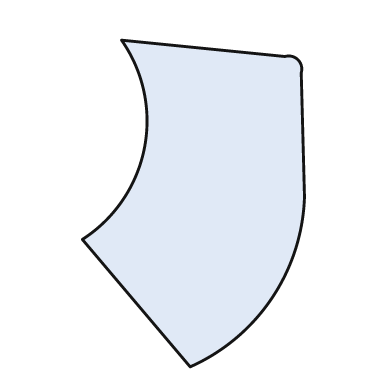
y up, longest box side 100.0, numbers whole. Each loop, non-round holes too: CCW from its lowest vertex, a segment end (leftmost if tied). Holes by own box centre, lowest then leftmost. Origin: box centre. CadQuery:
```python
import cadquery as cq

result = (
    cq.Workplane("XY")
    .moveTo(-1.0, -50.0)
    .threePointArc((24.0, -29.0), (34.0, 2.0))
    .lineTo(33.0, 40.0)
    .threePointArc((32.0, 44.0), (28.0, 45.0))
    .lineTo(-22.0, 50.0)
    .threePointArc((-15.0, 17.0), (-34.0, -11.0))
    .close()
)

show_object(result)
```